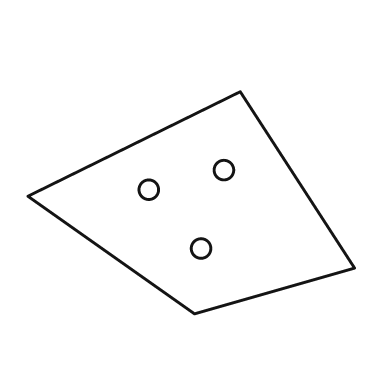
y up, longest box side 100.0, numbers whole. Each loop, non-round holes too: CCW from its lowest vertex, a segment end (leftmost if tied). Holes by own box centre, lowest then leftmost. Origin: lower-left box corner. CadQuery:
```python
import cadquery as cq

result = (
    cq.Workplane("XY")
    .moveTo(51.0, 0.0)
    .lineTo(100.0, 14.0)
    .lineTo(65.0, 68.0)
    .lineTo(0.0, 36.0)
    .close()
    .moveTo(53.0, 20.0)
    .circle(3.0)
    .moveTo(37.0, 38.0)
    .circle(3.0)
    .moveTo(60.0, 44.0)
    .circle(3.0)
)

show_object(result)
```